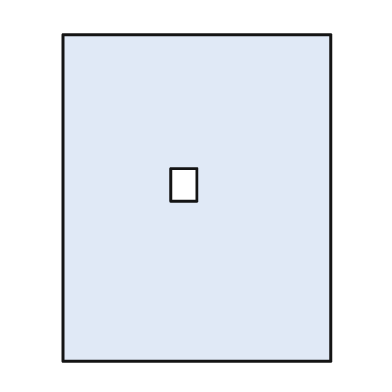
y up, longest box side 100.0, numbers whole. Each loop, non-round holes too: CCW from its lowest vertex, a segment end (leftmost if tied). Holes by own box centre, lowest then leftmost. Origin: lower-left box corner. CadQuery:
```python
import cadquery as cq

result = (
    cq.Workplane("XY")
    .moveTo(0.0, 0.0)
    .lineTo(82.0, 0.0)
    .lineTo(82.0, 100.0)
    .lineTo(0.0, 100.0)
    .close()
    .moveTo(33.0, 49.0)
    .lineTo(41.0, 49.0)
    .lineTo(41.0, 59.0)
    .lineTo(33.0, 59.0)
    .close()
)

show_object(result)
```